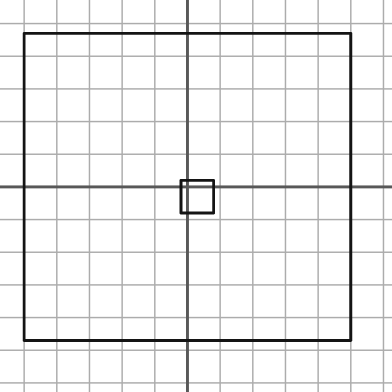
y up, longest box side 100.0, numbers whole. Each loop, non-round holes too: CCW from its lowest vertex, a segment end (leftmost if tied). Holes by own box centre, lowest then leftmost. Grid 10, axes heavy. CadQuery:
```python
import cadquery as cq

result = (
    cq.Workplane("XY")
    .moveTo(-50.0, -47.0)
    .lineTo(50.0, -47.0)
    .lineTo(50.0, 47.0)
    .lineTo(-50.0, 47.0)
    .close()
    .moveTo(-2.0, -8.0)
    .lineTo(8.0, -8.0)
    .lineTo(8.0, 2.0)
    .lineTo(-2.0, 2.0)
    .close()
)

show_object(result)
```